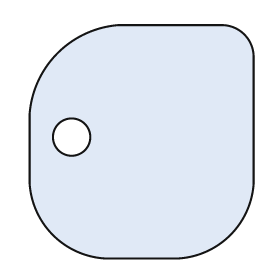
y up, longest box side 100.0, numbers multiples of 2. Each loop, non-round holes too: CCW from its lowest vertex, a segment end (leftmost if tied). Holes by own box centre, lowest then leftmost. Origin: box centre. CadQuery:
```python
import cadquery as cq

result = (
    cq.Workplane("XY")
    .moveTo(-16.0, -50.0)
    .lineTo(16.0, -50.0)
    .threePointArc((38.0, -40.0), (48.0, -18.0))
    .lineTo(48.0, 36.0)
    .threePointArc((44.0, 46.0), (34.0, 50.0))
    .lineTo(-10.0, 50.0)
    .threePointArc((-36.0, 38.0), (-48.0, 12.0))
    .lineTo(-48.0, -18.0)
    .threePointArc((-38.0, -40.0), (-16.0, -50.0))
    .close()
    .moveTo(-30.0, 2.0)
    .circle(8.0)
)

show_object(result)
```